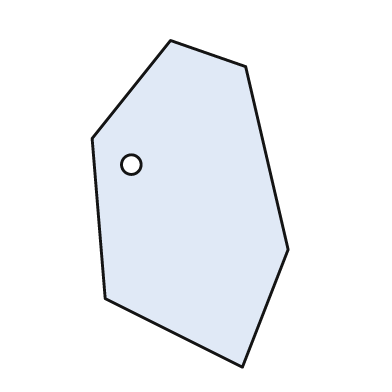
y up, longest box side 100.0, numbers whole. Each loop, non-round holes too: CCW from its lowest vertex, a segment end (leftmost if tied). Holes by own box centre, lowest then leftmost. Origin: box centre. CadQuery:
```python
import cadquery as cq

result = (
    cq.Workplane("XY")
    .moveTo(16.0, -50.0)
    .lineTo(30.0, -14.0)
    .lineTo(17.0, 42.0)
    .lineTo(-6.0, 50.0)
    .lineTo(-30.0, 20.0)
    .lineTo(-26.0, -29.0)
    .close()
    .moveTo(-18.0, 12.0)
    .circle(3.0)
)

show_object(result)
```